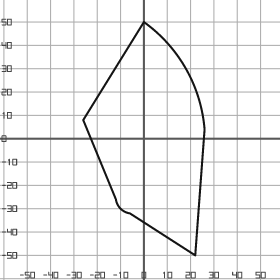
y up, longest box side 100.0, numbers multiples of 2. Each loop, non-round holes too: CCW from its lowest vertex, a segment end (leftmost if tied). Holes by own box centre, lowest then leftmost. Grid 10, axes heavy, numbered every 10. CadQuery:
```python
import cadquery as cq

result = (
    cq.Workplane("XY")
    .moveTo(22.0, -50.0)
    .lineTo(26.0, 4.0)
    .threePointArc((18.0, 30.0), (0.0, 50.0))
    .lineTo(-26.0, 8.0)
    .lineTo(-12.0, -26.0)
    .threePointArc((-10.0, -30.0), (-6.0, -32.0))
    .close()
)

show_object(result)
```